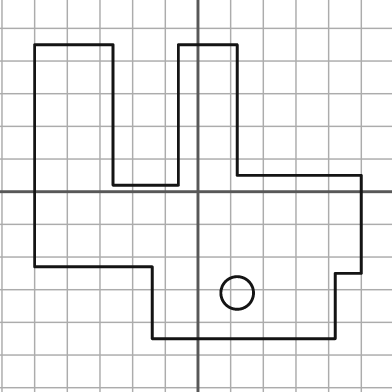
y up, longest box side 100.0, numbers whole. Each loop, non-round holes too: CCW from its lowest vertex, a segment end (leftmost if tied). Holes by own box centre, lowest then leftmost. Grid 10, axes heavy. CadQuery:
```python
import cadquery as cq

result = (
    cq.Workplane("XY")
    .moveTo(-14.0, -45.0)
    .lineTo(42.0, -45.0)
    .lineTo(42.0, -25.0)
    .lineTo(50.0, -25.0)
    .lineTo(50.0, 5.0)
    .lineTo(12.0, 5.0)
    .lineTo(12.0, 45.0)
    .lineTo(-6.0, 45.0)
    .lineTo(-6.0, 2.0)
    .lineTo(-26.0, 2.0)
    .lineTo(-26.0, 45.0)
    .lineTo(-50.0, 45.0)
    .lineTo(-50.0, -23.0)
    .lineTo(-14.0, -23.0)
    .close()
    .moveTo(12.0, -31.0)
    .circle(5.0)
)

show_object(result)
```